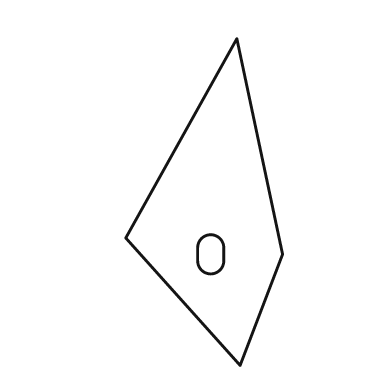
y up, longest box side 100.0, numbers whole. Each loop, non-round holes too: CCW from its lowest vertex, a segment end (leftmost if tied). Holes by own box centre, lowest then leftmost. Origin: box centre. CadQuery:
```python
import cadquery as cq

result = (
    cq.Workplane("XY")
    .moveTo(11.0, -50.0)
    .lineTo(24.0, -16.0)
    .lineTo(10.0, 50.0)
    .lineTo(-24.0, -11.0)
    .close()
    .moveTo(-2.0, -18.0)
    .threePointArc((2.0, -22.0), (6.0, -18.0))
    .lineTo(6.0, -14.0)
    .threePointArc((2.0, -10.0), (-2.0, -14.0))
    .close()
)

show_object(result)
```